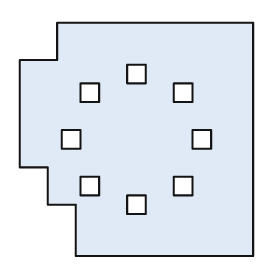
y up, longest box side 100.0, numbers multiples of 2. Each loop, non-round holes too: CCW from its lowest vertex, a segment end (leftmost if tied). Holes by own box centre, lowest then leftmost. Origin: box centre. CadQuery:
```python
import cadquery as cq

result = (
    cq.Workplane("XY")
    .moveTo(-26.0, -50.0)
    .lineTo(50.0, -50.0)
    .lineTo(50.0, 50.0)
    .lineTo(-34.0, 50.0)
    .lineTo(-34.0, 34.0)
    .lineTo(-50.0, 34.0)
    .lineTo(-50.0, -12.0)
    .lineTo(-38.0, -12.0)
    .lineTo(-38.0, -28.0)
    .lineTo(-26.0, -28.0)
    .close()
    .moveTo(-4.0, -32.0)
    .lineTo(4.0, -32.0)
    .lineTo(4.0, -24.0)
    .lineTo(-4.0, -24.0)
    .close()
    .moveTo(-24.0, -24.0)
    .lineTo(-16.0, -24.0)
    .lineTo(-16.0, -16.0)
    .lineTo(-24.0, -16.0)
    .close()
    .moveTo(16.0, -24.0)
    .lineTo(24.0, -24.0)
    .lineTo(24.0, -16.0)
    .lineTo(16.0, -16.0)
    .close()
    .moveTo(-32.0, -4.0)
    .lineTo(-24.0, -4.0)
    .lineTo(-24.0, 4.0)
    .lineTo(-32.0, 4.0)
    .close()
    .moveTo(24.0, -4.0)
    .lineTo(32.0, -4.0)
    .lineTo(32.0, 4.0)
    .lineTo(24.0, 4.0)
    .close()
    .moveTo(-24.0, 16.0)
    .lineTo(-16.0, 16.0)
    .lineTo(-16.0, 24.0)
    .lineTo(-24.0, 24.0)
    .close()
    .moveTo(16.0, 16.0)
    .lineTo(24.0, 16.0)
    .lineTo(24.0, 24.0)
    .lineTo(16.0, 24.0)
    .close()
    .moveTo(-4.0, 24.0)
    .lineTo(4.0, 24.0)
    .lineTo(4.0, 32.0)
    .lineTo(-4.0, 32.0)
    .close()
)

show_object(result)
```